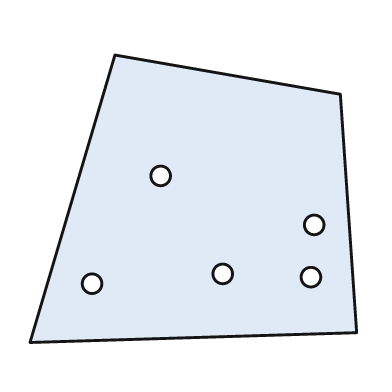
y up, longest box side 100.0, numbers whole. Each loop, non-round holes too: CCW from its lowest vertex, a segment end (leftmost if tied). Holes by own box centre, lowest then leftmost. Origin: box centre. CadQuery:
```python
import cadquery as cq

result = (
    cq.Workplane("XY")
    .moveTo(-50.0, -44.0)
    .lineTo(50.0, -41.0)
    .lineTo(45.0, 32.0)
    .lineTo(-24.0, 44.0)
    .close()
    .moveTo(-31.0, -26.0)
    .circle(3.0)
    .moveTo(36.0, -24.0)
    .circle(3.0)
    .moveTo(9.0, -23.0)
    .circle(3.0)
    .moveTo(37.0, -8.0)
    .circle(3.0)
    .moveTo(-10.0, 7.0)
    .circle(3.0)
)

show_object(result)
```